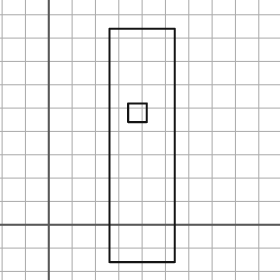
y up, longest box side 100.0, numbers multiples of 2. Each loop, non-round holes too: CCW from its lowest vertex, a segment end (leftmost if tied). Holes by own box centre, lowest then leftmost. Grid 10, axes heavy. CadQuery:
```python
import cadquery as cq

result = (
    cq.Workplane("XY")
    .moveTo(26.0, -16.0)
    .lineTo(54.0, -16.0)
    .lineTo(54.0, 84.0)
    .lineTo(26.0, 84.0)
    .close()
    .moveTo(34.0, 44.0)
    .lineTo(42.0, 44.0)
    .lineTo(42.0, 52.0)
    .lineTo(34.0, 52.0)
    .close()
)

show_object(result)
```